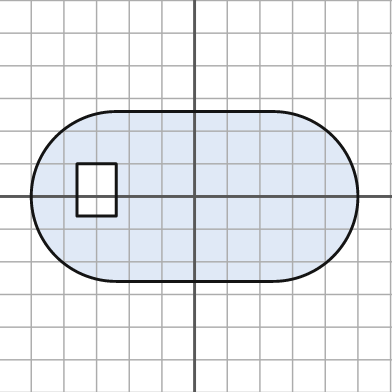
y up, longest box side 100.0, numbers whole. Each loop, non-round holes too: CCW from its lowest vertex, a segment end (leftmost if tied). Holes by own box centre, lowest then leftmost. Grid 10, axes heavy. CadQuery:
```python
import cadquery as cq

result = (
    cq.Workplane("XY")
    .moveTo(-24.0, -26.0)
    .lineTo(24.0, -26.0)
    .threePointArc((50.0, 0.0), (24.0, 26.0))
    .lineTo(-24.0, 26.0)
    .threePointArc((-50.0, 0.0), (-24.0, -26.0))
    .close()
    .moveTo(-36.0, -6.0)
    .lineTo(-24.0, -6.0)
    .lineTo(-24.0, 10.0)
    .lineTo(-36.0, 10.0)
    .close()
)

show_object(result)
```